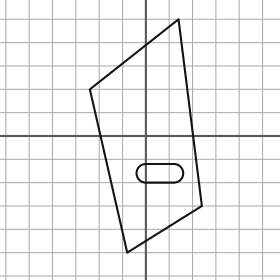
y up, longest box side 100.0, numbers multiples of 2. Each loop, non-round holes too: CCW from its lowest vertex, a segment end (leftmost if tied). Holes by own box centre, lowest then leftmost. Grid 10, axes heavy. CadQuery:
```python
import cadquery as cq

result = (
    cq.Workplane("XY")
    .moveTo(-8.0, -50.0)
    .lineTo(24.0, -30.0)
    .lineTo(14.0, 50.0)
    .lineTo(-24.0, 20.0)
    .close()
    .moveTo(0.0, -20.0)
    .lineTo(12.0, -20.0)
    .threePointArc((16.0, -16.0), (12.0, -12.0))
    .lineTo(0.0, -12.0)
    .threePointArc((-4.0, -16.0), (0.0, -20.0))
    .close()
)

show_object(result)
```